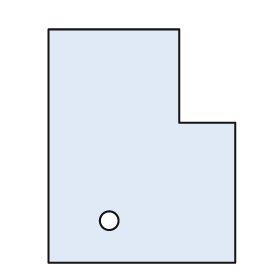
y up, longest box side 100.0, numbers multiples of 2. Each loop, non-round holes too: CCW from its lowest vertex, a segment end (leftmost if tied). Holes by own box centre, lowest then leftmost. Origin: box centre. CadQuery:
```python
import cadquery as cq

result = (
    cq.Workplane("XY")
    .moveTo(-40.0, -50.0)
    .lineTo(40.0, -50.0)
    .lineTo(40.0, 10.0)
    .lineTo(16.0, 10.0)
    .lineTo(16.0, 50.0)
    .lineTo(-40.0, 50.0)
    .close()
    .moveTo(-14.0, -32.0)
    .circle(4.0)
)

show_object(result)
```